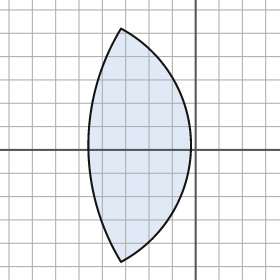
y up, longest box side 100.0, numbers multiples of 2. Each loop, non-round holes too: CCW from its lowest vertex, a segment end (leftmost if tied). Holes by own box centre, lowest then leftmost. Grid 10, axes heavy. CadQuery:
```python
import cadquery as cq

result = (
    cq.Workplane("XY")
    .moveTo(-32.0, -48.0)
    .threePointArc((-2.0, 2.0), (-32.0, 52.0))
    .threePointArc((-46.0, 2.0), (-32.0, -48.0))
    .close()
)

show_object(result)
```